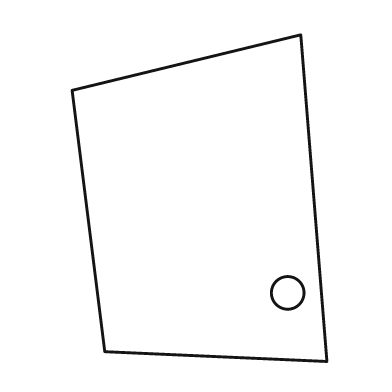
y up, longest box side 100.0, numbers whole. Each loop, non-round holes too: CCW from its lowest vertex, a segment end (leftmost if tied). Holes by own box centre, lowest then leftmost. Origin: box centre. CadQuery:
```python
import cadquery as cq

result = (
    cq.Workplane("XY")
    .moveTo(39.0, -50.0)
    .lineTo(31.0, 50.0)
    .lineTo(-39.0, 33.0)
    .lineTo(-29.0, -47.0)
    .close()
    .moveTo(27.0, -29.0)
    .circle(5.0)
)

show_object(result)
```